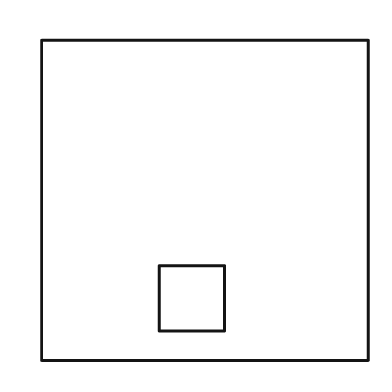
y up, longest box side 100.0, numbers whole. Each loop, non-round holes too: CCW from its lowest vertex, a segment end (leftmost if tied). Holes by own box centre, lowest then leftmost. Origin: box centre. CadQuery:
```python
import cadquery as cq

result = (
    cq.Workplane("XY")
    .moveTo(-50.0, -49.0)
    .lineTo(50.0, -49.0)
    .lineTo(50.0, 49.0)
    .lineTo(-50.0, 49.0)
    .close()
    .moveTo(-14.0, -40.0)
    .lineTo(6.0, -40.0)
    .lineTo(6.0, -20.0)
    .lineTo(-14.0, -20.0)
    .close()
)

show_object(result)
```